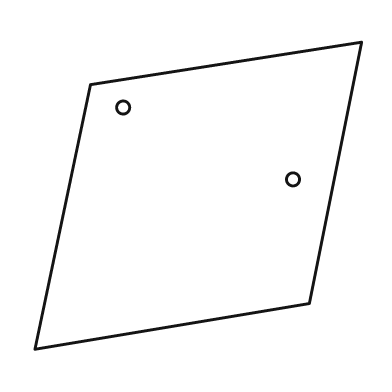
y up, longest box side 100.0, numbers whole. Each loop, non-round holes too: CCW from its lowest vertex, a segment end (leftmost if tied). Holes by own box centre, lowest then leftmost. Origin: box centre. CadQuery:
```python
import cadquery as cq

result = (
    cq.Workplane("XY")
    .moveTo(-50.0, -47.0)
    .lineTo(34.0, -33.0)
    .lineTo(50.0, 47.0)
    .lineTo(-33.0, 34.0)
    .close()
    .moveTo(29.0, 5.0)
    .circle(2.0)
    .moveTo(-23.0, 27.0)
    .circle(2.0)
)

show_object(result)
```